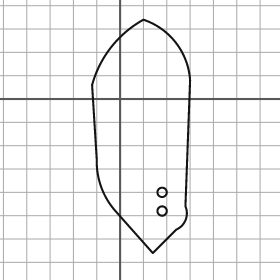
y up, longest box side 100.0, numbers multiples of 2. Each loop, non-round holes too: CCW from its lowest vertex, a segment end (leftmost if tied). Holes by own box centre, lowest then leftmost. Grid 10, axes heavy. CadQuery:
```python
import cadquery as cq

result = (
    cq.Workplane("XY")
    .moveTo(14.0, -66.0)
    .lineTo(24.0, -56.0)
    .threePointArc((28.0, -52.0), (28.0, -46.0))
    .lineTo(30.0, 8.0)
    .threePointArc((24.0, 24.0), (10.0, 34.0))
    .threePointArc((-4.0, 22.0), (-12.0, 6.0))
    .lineTo(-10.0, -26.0)
    .threePointArc((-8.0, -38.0), (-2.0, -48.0))
    .close()
    .moveTo(18.0, -48.0)
    .circle(2.0)
    .moveTo(18.0, -40.0)
    .circle(2.0)
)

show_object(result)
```